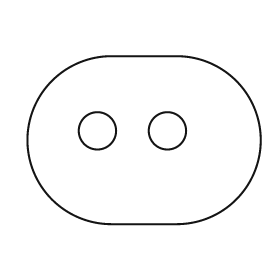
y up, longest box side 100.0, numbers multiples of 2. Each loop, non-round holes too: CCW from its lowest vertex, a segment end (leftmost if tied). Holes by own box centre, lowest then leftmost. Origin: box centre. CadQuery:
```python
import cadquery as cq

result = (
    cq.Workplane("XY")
    .moveTo(-14.0, -36.0)
    .lineTo(14.0, -36.0)
    .threePointArc((50.0, 0.0), (14.0, 36.0))
    .lineTo(-14.0, 36.0)
    .threePointArc((-50.0, 0.0), (-14.0, -36.0))
    .close()
    .moveTo(-20.0, 4.0)
    .circle(8.0)
    .moveTo(10.0, 4.0)
    .circle(8.0)
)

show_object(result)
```